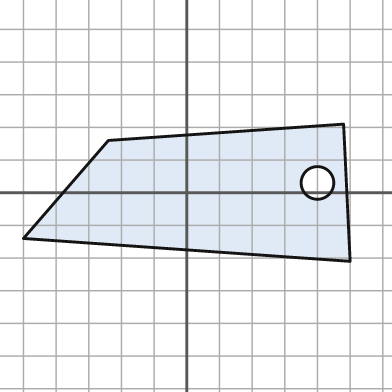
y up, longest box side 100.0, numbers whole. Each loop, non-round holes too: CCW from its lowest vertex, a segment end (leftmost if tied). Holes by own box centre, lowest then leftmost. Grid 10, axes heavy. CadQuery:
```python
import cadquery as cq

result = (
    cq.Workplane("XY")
    .moveTo(50.0, -21.0)
    .lineTo(48.0, 21.0)
    .lineTo(-24.0, 16.0)
    .lineTo(-50.0, -14.0)
    .close()
    .moveTo(40.0, 3.0)
    .circle(5.0)
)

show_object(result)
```